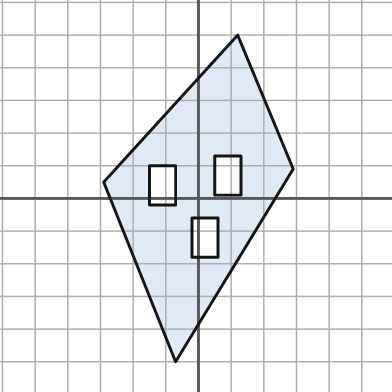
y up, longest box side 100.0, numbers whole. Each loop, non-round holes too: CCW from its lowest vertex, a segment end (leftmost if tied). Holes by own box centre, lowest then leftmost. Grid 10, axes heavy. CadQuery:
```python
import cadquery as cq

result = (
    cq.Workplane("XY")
    .moveTo(-7.0, -50.0)
    .lineTo(29.0, 9.0)
    .lineTo(12.0, 50.0)
    .lineTo(-29.0, 5.0)
    .close()
    .moveTo(-2.0, -18.0)
    .lineTo(6.0, -18.0)
    .lineTo(6.0, -6.0)
    .lineTo(-2.0, -6.0)
    .close()
    .moveTo(-15.0, -2.0)
    .lineTo(-7.0, -2.0)
    .lineTo(-7.0, 10.0)
    .lineTo(-15.0, 10.0)
    .close()
    .moveTo(5.0, 1.0)
    .lineTo(13.0, 1.0)
    .lineTo(13.0, 13.0)
    .lineTo(5.0, 13.0)
    .close()
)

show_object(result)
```